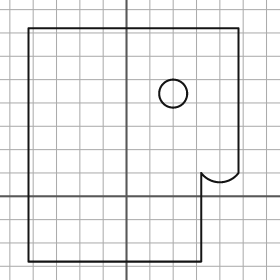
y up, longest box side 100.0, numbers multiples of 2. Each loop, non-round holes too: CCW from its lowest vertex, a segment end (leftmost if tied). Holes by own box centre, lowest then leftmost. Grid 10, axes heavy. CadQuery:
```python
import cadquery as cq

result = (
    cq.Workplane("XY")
    .moveTo(-42.0, -28.0)
    .lineTo(32.0, -28.0)
    .lineTo(32.0, 10.0)
    .threePointArc((40.0, 6.0), (48.0, 10.0))
    .lineTo(48.0, 72.0)
    .lineTo(-42.0, 72.0)
    .close()
    .moveTo(20.0, 44.0)
    .circle(6.0)
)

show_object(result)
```